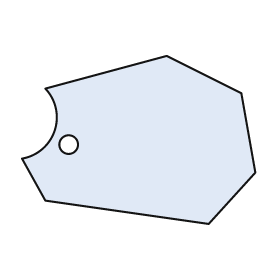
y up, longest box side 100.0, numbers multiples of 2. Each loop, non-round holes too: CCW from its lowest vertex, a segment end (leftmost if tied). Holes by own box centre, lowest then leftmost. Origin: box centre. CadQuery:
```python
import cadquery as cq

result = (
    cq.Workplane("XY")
    .moveTo(30.0, -36.0)
    .lineTo(50.0, -14.0)
    .lineTo(44.0, 20.0)
    .lineTo(12.0, 36.0)
    .lineTo(-40.0, 22.0)
    .threePointArc((-36.0, 4.0), (-50.0, -8.0))
    .lineTo(-40.0, -26.0)
    .close()
    .moveTo(-30.0, -2.0)
    .circle(4.0)
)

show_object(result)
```